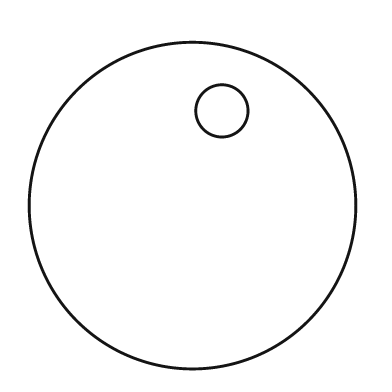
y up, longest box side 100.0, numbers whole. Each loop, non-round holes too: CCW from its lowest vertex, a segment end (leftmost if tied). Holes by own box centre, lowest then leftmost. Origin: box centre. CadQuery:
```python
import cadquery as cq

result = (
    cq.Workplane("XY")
    .moveTo(0.0, 0.0)
    .circle(50.0)
    .moveTo(9.0, 29.0)
    .circle(8.0)
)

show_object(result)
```